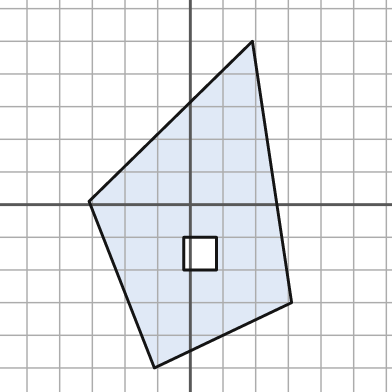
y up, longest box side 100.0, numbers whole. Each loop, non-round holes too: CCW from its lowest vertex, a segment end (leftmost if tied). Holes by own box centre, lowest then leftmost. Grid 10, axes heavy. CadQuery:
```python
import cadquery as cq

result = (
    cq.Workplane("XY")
    .moveTo(-11.0, -50.0)
    .lineTo(31.0, -30.0)
    .lineTo(19.0, 50.0)
    .lineTo(-31.0, 1.0)
    .close()
    .moveTo(-2.0, -20.0)
    .lineTo(8.0, -20.0)
    .lineTo(8.0, -10.0)
    .lineTo(-2.0, -10.0)
    .close()
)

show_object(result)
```